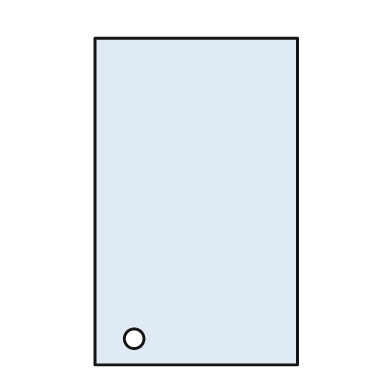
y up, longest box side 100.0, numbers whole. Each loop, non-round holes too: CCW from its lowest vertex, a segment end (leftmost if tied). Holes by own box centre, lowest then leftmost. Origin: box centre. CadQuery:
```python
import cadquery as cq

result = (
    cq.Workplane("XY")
    .moveTo(-31.0, -50.0)
    .lineTo(31.0, -50.0)
    .lineTo(31.0, 50.0)
    .lineTo(-31.0, 50.0)
    .close()
    .moveTo(-19.0, -42.0)
    .circle(3.0)
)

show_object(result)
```